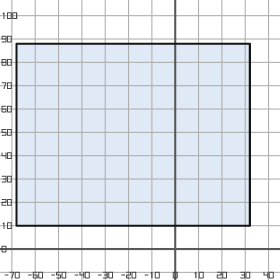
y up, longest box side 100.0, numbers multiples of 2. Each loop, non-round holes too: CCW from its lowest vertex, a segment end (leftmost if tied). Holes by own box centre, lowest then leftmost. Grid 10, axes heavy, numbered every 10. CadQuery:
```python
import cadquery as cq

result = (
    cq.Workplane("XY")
    .moveTo(-68.0, 10.0)
    .lineTo(32.0, 10.0)
    .lineTo(32.0, 88.0)
    .lineTo(-68.0, 88.0)
    .close()
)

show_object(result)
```